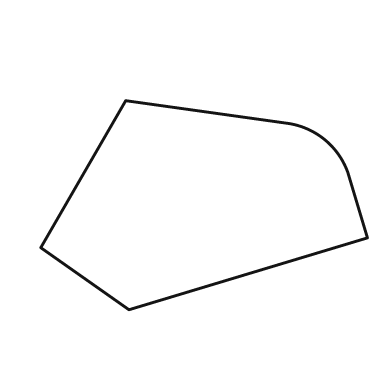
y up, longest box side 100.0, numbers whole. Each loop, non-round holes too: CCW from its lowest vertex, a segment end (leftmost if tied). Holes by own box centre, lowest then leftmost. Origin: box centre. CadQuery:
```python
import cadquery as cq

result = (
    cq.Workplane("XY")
    .moveTo(-23.0, -32.0)
    .lineTo(50.0, -10.0)
    .lineTo(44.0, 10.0)
    .threePointArc((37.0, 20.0), (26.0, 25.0))
    .lineTo(-24.0, 32.0)
    .lineTo(-50.0, -13.0)
    .close()
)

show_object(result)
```